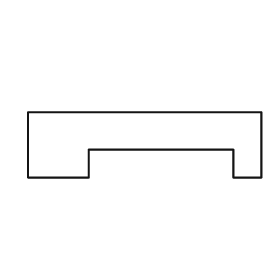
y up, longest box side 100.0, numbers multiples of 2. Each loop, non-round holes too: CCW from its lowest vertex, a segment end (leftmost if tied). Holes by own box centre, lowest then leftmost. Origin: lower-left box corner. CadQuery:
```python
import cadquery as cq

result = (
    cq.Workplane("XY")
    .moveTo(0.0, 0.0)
    .lineTo(26.0, 0.0)
    .lineTo(26.0, 12.0)
    .lineTo(88.0, 12.0)
    .lineTo(88.0, 0.0)
    .lineTo(100.0, 0.0)
    .lineTo(100.0, 28.0)
    .lineTo(0.0, 28.0)
    .close()
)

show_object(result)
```